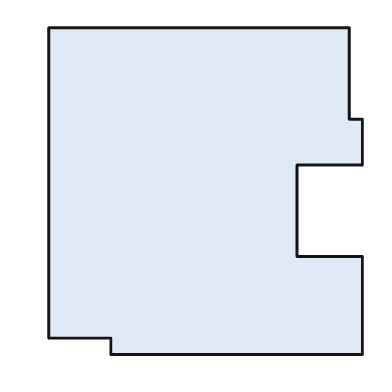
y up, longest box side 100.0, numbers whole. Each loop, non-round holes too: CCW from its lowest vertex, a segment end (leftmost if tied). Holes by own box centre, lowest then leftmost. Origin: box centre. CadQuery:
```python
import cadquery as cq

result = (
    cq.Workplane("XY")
    .moveTo(-29.0, -50.0)
    .lineTo(48.0, -50.0)
    .lineTo(48.0, -20.0)
    .lineTo(28.0, -20.0)
    .lineTo(28.0, 8.0)
    .lineTo(48.0, 8.0)
    .lineTo(48.0, 22.0)
    .lineTo(44.0, 22.0)
    .lineTo(44.0, 50.0)
    .lineTo(-48.0, 50.0)
    .lineTo(-48.0, -45.0)
    .lineTo(-29.0, -45.0)
    .close()
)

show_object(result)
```